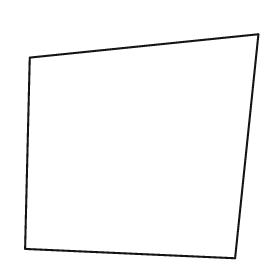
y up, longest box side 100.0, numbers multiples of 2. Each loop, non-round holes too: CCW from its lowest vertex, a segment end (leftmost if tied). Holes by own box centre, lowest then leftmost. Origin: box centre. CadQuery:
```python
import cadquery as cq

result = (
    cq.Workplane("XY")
    .moveTo(40.0, -48.0)
    .lineTo(50.0, 48.0)
    .lineTo(-48.0, 38.0)
    .lineTo(-50.0, -44.0)
    .close()
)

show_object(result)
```